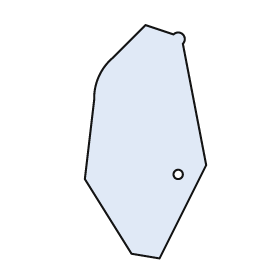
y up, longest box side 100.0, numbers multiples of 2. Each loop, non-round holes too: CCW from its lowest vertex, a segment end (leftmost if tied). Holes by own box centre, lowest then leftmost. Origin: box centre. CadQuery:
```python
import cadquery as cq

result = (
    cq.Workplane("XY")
    .moveTo(6.0, -50.0)
    .lineTo(26.0, -10.0)
    .lineTo(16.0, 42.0)
    .threePointArc((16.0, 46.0), (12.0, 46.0))
    .lineTo(0.0, 50.0)
    .lineTo(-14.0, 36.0)
    .threePointArc((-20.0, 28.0), (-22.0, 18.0))
    .lineTo(-26.0, -16.0)
    .lineTo(-6.0, -48.0)
    .close()
    .moveTo(14.0, -14.0)
    .circle(2.0)
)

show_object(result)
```